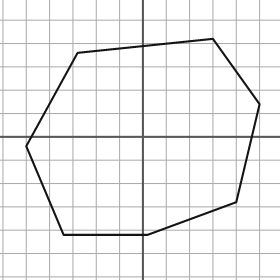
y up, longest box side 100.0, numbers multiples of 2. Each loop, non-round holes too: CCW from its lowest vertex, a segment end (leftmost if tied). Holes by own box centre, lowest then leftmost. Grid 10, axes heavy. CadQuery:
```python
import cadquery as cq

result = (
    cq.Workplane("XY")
    .moveTo(-34.0, -42.0)
    .lineTo(2.0, -42.0)
    .lineTo(40.0, -28.0)
    .lineTo(50.0, 14.0)
    .lineTo(30.0, 42.0)
    .lineTo(-28.0, 36.0)
    .lineTo(-50.0, -4.0)
    .close()
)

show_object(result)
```